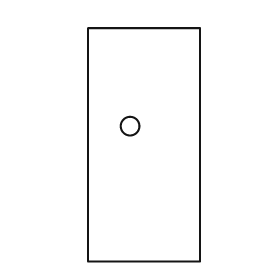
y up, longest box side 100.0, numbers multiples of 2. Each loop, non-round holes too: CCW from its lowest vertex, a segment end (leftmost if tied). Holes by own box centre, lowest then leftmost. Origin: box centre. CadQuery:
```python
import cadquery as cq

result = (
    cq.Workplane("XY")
    .moveTo(-24.0, -50.0)
    .lineTo(24.0, -50.0)
    .lineTo(24.0, 50.0)
    .lineTo(-24.0, 50.0)
    .close()
    .moveTo(-6.0, 8.0)
    .circle(4.0)
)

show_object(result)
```